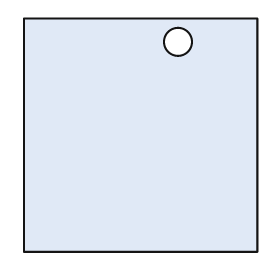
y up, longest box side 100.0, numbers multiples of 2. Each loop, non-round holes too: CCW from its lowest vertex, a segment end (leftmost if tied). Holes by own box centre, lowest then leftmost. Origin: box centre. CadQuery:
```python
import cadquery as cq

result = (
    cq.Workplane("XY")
    .moveTo(-50.0, -50.0)
    .lineTo(50.0, -50.0)
    .lineTo(50.0, 50.0)
    .lineTo(-50.0, 50.0)
    .close()
    .moveTo(16.0, 40.0)
    .circle(6.0)
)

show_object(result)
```